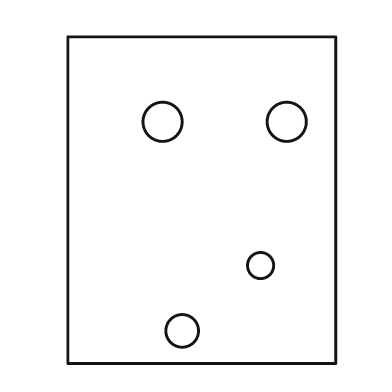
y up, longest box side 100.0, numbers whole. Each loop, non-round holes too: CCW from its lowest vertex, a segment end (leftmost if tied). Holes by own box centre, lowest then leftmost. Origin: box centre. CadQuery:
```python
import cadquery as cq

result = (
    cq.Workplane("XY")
    .moveTo(-41.0, -50.0)
    .lineTo(41.0, -50.0)
    .lineTo(41.0, 50.0)
    .lineTo(-41.0, 50.0)
    .close()
    .moveTo(-6.0, -40.0)
    .circle(5.0)
    .moveTo(18.0, -20.0)
    .circle(4.0)
    .moveTo(-12.0, 24.0)
    .circle(6.0)
    .moveTo(26.0, 24.0)
    .circle(6.0)
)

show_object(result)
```